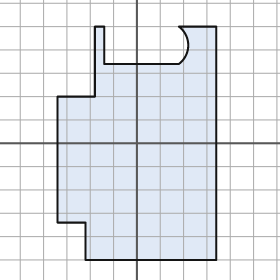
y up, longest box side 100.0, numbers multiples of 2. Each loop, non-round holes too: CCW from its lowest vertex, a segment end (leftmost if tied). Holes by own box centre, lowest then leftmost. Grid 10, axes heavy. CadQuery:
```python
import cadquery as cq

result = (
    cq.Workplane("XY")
    .moveTo(-22.0, -50.0)
    .lineTo(34.0, -50.0)
    .lineTo(34.0, 50.0)
    .lineTo(18.0, 50.0)
    .threePointArc((22.0, 42.0), (18.0, 34.0))
    .lineTo(-14.0, 34.0)
    .lineTo(-14.0, 50.0)
    .lineTo(-18.0, 50.0)
    .lineTo(-18.0, 20.0)
    .lineTo(-34.0, 20.0)
    .lineTo(-34.0, -34.0)
    .lineTo(-22.0, -34.0)
    .close()
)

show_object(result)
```